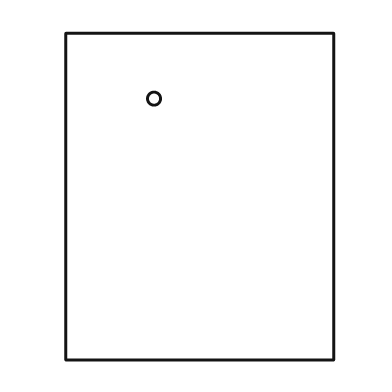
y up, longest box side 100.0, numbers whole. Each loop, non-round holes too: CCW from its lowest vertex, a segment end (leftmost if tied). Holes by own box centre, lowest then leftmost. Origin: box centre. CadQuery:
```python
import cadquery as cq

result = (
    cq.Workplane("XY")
    .moveTo(-41.0, -50.0)
    .lineTo(41.0, -50.0)
    .lineTo(41.0, 50.0)
    .lineTo(-41.0, 50.0)
    .close()
    .moveTo(-14.0, 30.0)
    .circle(2.0)
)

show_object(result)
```